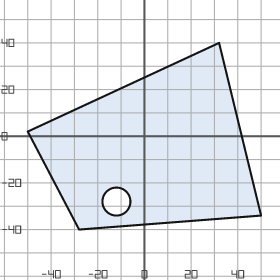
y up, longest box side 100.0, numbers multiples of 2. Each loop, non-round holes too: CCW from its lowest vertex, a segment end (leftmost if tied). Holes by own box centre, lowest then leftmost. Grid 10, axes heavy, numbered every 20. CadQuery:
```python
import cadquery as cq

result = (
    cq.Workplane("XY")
    .moveTo(-28.0, -40.0)
    .lineTo(50.0, -34.0)
    .lineTo(32.0, 40.0)
    .lineTo(-50.0, 2.0)
    .close()
    .moveTo(-12.0, -28.0)
    .circle(6.0)
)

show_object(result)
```